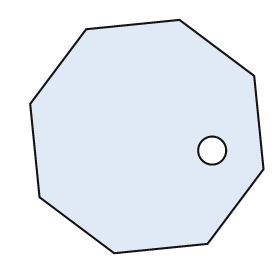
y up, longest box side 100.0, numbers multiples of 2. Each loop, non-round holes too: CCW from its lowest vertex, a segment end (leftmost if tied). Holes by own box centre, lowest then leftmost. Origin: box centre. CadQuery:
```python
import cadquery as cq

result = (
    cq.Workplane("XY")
    .moveTo(-14.0, -50.0)
    .lineTo(26.0, -46.0)
    .lineTo(50.0, -14.0)
    .lineTo(46.0, 26.0)
    .lineTo(14.0, 50.0)
    .lineTo(-26.0, 46.0)
    .lineTo(-50.0, 14.0)
    .lineTo(-46.0, -26.0)
    .close()
    .moveTo(28.0, -6.0)
    .circle(6.0)
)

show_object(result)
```